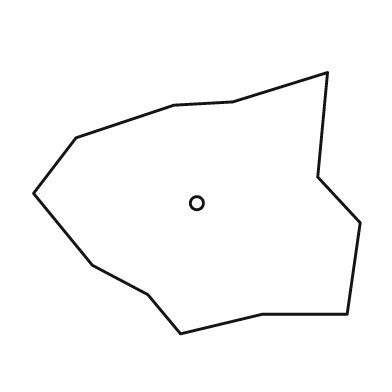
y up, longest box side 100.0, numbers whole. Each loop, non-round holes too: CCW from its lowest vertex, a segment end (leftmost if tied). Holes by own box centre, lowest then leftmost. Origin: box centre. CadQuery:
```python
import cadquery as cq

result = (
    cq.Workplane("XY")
    .moveTo(-5.0, -40.0)
    .lineTo(20.0, -34.0)
    .lineTo(46.0, -34.0)
    .lineTo(50.0, -6.0)
    .lineTo(37.0, 8.0)
    .lineTo(40.0, 40.0)
    .lineTo(11.0, 31.0)
    .lineTo(-7.0, 30.0)
    .lineTo(-37.0, 20.0)
    .lineTo(-50.0, 3.0)
    .lineTo(-32.0, -19.0)
    .lineTo(-15.0, -28.0)
    .close()
    .moveTo(0.0, 0.0)
    .circle(2.0)
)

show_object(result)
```